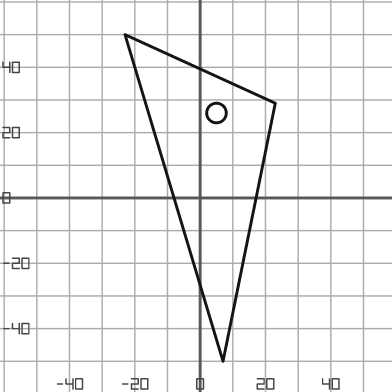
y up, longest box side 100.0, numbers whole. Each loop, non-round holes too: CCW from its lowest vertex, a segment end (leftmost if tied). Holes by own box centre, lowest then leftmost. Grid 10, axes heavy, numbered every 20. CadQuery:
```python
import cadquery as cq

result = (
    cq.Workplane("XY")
    .moveTo(7.0, -50.0)
    .lineTo(23.0, 29.0)
    .lineTo(-23.0, 50.0)
    .close()
    .moveTo(5.0, 26.0)
    .circle(3.0)
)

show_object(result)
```